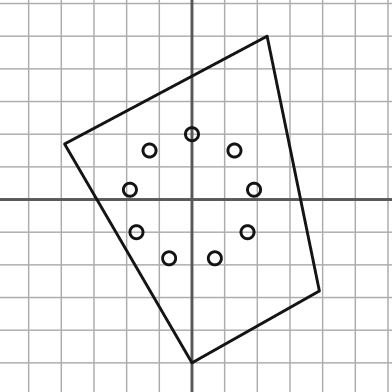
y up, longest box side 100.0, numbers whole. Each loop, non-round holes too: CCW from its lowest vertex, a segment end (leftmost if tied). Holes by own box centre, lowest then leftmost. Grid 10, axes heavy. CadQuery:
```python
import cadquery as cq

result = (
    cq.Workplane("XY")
    .moveTo(0.0, -50.0)
    .lineTo(39.0, -28.0)
    .lineTo(23.0, 50.0)
    .lineTo(-39.0, 17.0)
    .close()
    .moveTo(-7.0, -18.0)
    .circle(2.0)
    .moveTo(7.0, -18.0)
    .circle(2.0)
    .moveTo(-17.0, -10.0)
    .circle(2.0)
    .moveTo(17.0, -10.0)
    .circle(2.0)
    .moveTo(-19.0, 3.0)
    .circle(2.0)
    .moveTo(19.0, 3.0)
    .circle(2.0)
    .moveTo(-13.0, 15.0)
    .circle(2.0)
    .moveTo(13.0, 15.0)
    .circle(2.0)
    .moveTo(0.0, 20.0)
    .circle(2.0)
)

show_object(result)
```